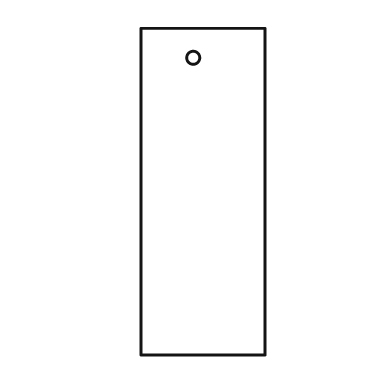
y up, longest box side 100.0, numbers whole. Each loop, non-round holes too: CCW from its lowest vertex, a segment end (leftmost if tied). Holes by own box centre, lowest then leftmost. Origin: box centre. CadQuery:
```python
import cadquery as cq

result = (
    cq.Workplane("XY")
    .moveTo(-19.0, -50.0)
    .lineTo(19.0, -50.0)
    .lineTo(19.0, 50.0)
    .lineTo(-19.0, 50.0)
    .close()
    .moveTo(-3.0, 41.0)
    .circle(2.0)
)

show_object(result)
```